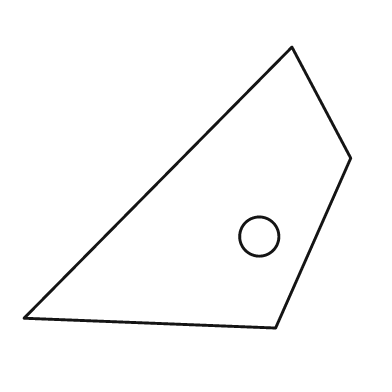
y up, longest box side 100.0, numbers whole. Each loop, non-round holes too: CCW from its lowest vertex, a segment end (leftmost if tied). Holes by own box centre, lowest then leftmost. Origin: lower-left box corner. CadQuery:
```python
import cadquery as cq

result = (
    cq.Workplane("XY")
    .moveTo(77.0, 0.0)
    .lineTo(100.0, 52.0)
    .lineTo(82.0, 86.0)
    .lineTo(0.0, 3.0)
    .close()
    .moveTo(72.0, 28.0)
    .circle(6.0)
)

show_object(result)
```